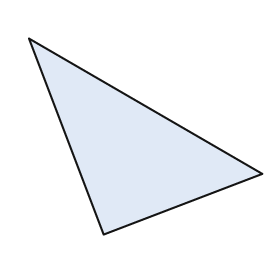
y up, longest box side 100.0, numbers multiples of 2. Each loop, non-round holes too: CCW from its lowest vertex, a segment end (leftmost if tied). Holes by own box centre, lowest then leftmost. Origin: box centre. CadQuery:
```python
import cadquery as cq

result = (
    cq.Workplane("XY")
    .moveTo(-18.0, -42.0)
    .lineTo(50.0, -16.0)
    .lineTo(-50.0, 42.0)
    .close()
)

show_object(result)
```